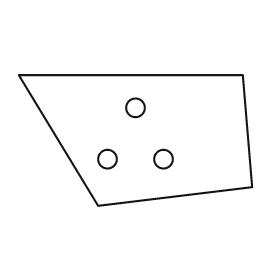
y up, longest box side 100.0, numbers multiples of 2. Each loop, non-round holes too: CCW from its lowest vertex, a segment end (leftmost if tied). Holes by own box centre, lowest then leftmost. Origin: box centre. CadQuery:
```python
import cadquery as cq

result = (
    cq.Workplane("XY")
    .moveTo(-16.0, -28.0)
    .lineTo(50.0, -20.0)
    .lineTo(46.0, 28.0)
    .lineTo(-50.0, 28.0)
    .close()
    .moveTo(-12.0, -8.0)
    .circle(4.0)
    .moveTo(12.0, -8.0)
    .circle(4.0)
    .moveTo(0.0, 14.0)
    .circle(4.0)
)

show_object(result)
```